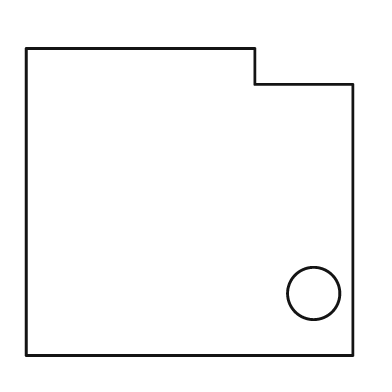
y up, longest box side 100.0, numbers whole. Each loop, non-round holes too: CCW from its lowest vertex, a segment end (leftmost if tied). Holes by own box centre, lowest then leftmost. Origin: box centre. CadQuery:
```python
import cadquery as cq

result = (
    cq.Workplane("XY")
    .moveTo(-50.0, -47.0)
    .lineTo(50.0, -47.0)
    .lineTo(50.0, 36.0)
    .lineTo(20.0, 36.0)
    .lineTo(20.0, 47.0)
    .lineTo(-50.0, 47.0)
    .close()
    .moveTo(38.0, -28.0)
    .circle(8.0)
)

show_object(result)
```